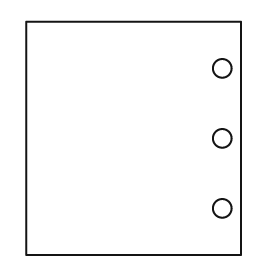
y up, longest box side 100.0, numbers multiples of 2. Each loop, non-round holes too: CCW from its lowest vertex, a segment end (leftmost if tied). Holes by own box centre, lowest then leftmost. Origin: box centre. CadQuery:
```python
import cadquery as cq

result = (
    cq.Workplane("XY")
    .moveTo(-46.0, -50.0)
    .lineTo(46.0, -50.0)
    .lineTo(46.0, 50.0)
    .lineTo(-46.0, 50.0)
    .close()
    .moveTo(38.0, -30.0)
    .circle(4.0)
    .moveTo(38.0, 0.0)
    .circle(4.0)
    .moveTo(38.0, 30.0)
    .circle(4.0)
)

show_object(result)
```